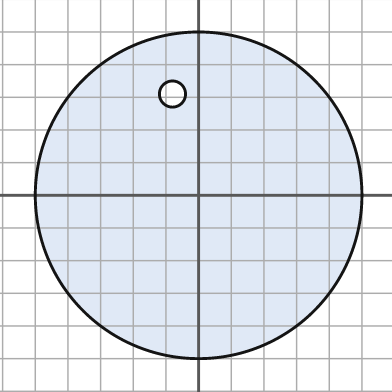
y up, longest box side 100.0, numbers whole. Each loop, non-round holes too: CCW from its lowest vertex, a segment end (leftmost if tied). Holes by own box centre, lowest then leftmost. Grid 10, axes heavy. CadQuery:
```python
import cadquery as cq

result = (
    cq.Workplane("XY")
    .moveTo(0.0, 0.0)
    .circle(50.0)
    .moveTo(-8.0, 31.0)
    .circle(4.0)
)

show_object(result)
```